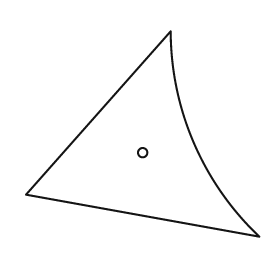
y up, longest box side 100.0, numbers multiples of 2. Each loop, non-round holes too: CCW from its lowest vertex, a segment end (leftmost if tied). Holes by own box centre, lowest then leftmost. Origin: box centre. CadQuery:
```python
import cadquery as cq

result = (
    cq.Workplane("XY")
    .moveTo(50.0, -44.0)
    .threePointArc((22.0, -4.0), (12.0, 44.0))
    .lineTo(-50.0, -26.0)
    .close()
    .moveTo(0.0, -8.0)
    .circle(2.0)
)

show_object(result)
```